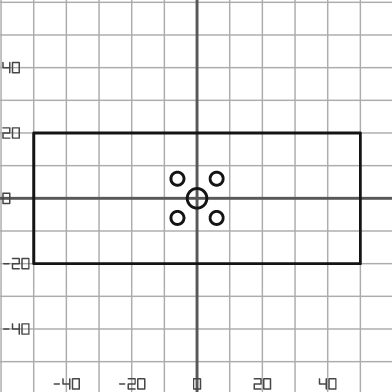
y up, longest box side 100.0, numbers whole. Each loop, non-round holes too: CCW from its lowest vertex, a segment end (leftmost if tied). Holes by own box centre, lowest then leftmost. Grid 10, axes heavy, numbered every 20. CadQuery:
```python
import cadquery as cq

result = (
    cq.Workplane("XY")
    .moveTo(-50.0, -20.0)
    .lineTo(50.0, -20.0)
    .lineTo(50.0, 20.0)
    .lineTo(-50.0, 20.0)
    .close()
    .moveTo(-6.0, -6.0)
    .circle(2.0)
    .moveTo(6.0, -6.0)
    .circle(2.0)
    .moveTo(0.0, 0.0)
    .circle(3.0)
    .moveTo(-6.0, 6.0)
    .circle(2.0)
    .moveTo(6.0, 6.0)
    .circle(2.0)
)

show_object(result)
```